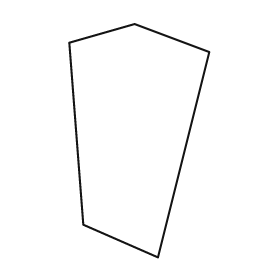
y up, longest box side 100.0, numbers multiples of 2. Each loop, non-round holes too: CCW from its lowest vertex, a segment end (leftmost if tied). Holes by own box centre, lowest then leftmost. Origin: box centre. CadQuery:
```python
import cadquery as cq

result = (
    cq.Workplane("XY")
    .moveTo(8.0, -50.0)
    .lineTo(30.0, 38.0)
    .lineTo(-2.0, 50.0)
    .lineTo(-30.0, 42.0)
    .lineTo(-24.0, -36.0)
    .close()
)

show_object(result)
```